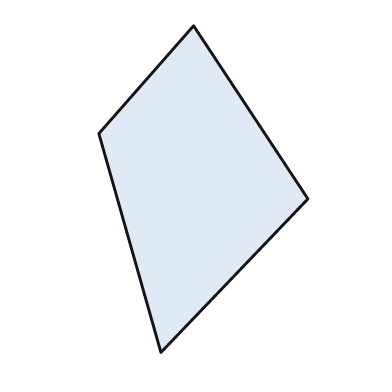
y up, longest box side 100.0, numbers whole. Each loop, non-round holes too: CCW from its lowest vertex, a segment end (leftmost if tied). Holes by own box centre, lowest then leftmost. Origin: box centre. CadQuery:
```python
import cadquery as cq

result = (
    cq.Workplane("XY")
    .moveTo(-13.0, -50.0)
    .lineTo(32.0, -3.0)
    .lineTo(-3.0, 50.0)
    .lineTo(-32.0, 17.0)
    .close()
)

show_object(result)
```